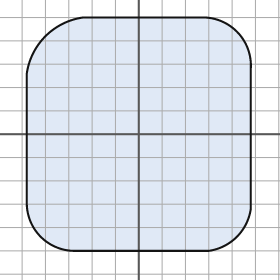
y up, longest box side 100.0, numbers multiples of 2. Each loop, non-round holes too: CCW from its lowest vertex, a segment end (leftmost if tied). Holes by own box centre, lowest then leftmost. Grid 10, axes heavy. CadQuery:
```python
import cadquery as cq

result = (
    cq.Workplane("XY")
    .moveTo(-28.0, -50.0)
    .lineTo(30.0, -50.0)
    .threePointArc((42.0, -44.0), (48.0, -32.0))
    .lineTo(48.0, 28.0)
    .threePointArc((42.0, 44.0), (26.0, 50.0))
    .lineTo(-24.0, 50.0)
    .threePointArc((-40.0, 42.0), (-48.0, 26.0))
    .lineTo(-48.0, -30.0)
    .threePointArc((-42.0, -44.0), (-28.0, -50.0))
    .close()
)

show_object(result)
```